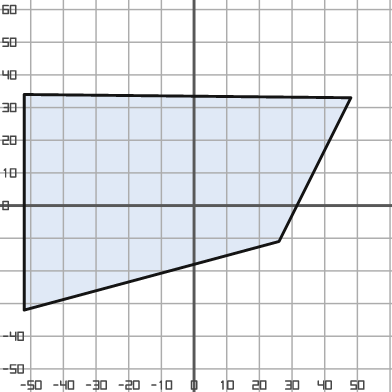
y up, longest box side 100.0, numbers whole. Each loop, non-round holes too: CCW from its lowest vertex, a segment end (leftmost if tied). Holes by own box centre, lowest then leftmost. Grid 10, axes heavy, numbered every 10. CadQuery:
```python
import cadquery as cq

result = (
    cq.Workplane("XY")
    .moveTo(-52.0, -32.0)
    .lineTo(26.0, -11.0)
    .lineTo(48.0, 33.0)
    .lineTo(-52.0, 34.0)
    .close()
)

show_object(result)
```